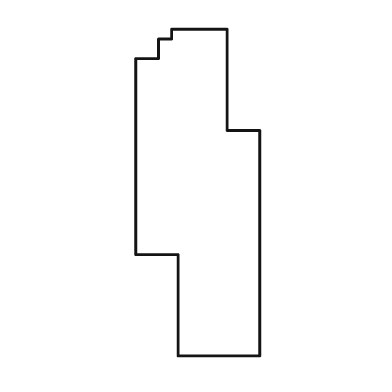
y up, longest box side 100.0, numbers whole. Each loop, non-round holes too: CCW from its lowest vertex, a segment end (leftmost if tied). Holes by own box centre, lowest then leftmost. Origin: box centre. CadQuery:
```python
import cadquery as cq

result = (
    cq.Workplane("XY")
    .moveTo(-6.0, -50.0)
    .lineTo(19.0, -50.0)
    .lineTo(19.0, 19.0)
    .lineTo(9.0, 19.0)
    .lineTo(9.0, 50.0)
    .lineTo(-8.0, 50.0)
    .lineTo(-8.0, 47.0)
    .lineTo(-12.0, 47.0)
    .lineTo(-12.0, 41.0)
    .lineTo(-19.0, 41.0)
    .lineTo(-19.0, -19.0)
    .lineTo(-6.0, -19.0)
    .close()
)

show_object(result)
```